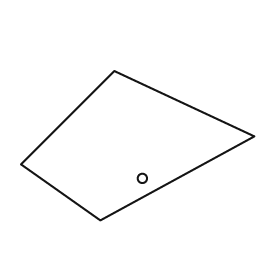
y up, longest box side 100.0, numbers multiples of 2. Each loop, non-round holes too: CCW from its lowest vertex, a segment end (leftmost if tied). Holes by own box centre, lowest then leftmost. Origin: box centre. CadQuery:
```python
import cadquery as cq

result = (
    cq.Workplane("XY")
    .moveTo(-16.0, -32.0)
    .lineTo(50.0, 4.0)
    .lineTo(-10.0, 32.0)
    .lineTo(-50.0, -8.0)
    .close()
    .moveTo(2.0, -14.0)
    .circle(2.0)
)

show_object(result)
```